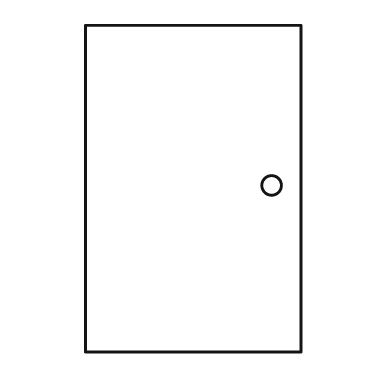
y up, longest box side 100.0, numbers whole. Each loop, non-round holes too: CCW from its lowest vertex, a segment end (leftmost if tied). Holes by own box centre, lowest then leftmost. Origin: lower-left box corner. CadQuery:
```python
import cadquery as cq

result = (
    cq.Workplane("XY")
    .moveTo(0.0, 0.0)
    .lineTo(66.0, 0.0)
    .lineTo(66.0, 100.0)
    .lineTo(0.0, 100.0)
    .close()
    .moveTo(57.0, 51.0)
    .circle(3.0)
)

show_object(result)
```